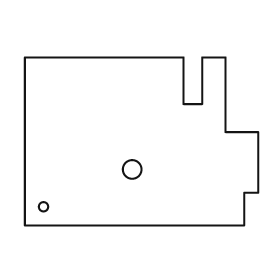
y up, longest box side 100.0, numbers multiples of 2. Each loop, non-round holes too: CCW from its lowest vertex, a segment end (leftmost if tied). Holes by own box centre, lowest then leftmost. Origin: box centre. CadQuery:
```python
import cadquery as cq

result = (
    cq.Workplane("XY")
    .moveTo(-50.0, -36.0)
    .lineTo(44.0, -36.0)
    .lineTo(44.0, -22.0)
    .lineTo(50.0, -22.0)
    .lineTo(50.0, 4.0)
    .lineTo(36.0, 4.0)
    .lineTo(36.0, 36.0)
    .lineTo(26.0, 36.0)
    .lineTo(26.0, 16.0)
    .lineTo(18.0, 16.0)
    .lineTo(18.0, 36.0)
    .lineTo(-50.0, 36.0)
    .close()
    .moveTo(-42.0, -28.0)
    .circle(2.0)
    .moveTo(-4.0, -12.0)
    .circle(4.0)
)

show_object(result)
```